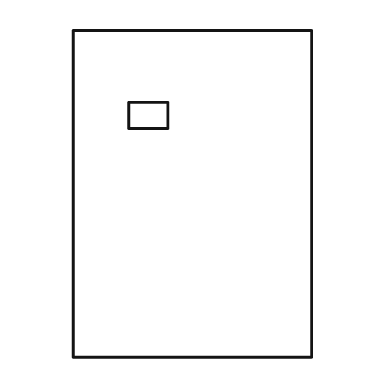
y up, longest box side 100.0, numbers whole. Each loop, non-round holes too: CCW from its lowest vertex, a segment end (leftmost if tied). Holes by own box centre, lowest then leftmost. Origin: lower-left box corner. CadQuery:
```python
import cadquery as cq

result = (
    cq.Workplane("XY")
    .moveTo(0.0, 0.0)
    .lineTo(73.0, 0.0)
    .lineTo(73.0, 100.0)
    .lineTo(0.0, 100.0)
    .close()
    .moveTo(17.0, 70.0)
    .lineTo(29.0, 70.0)
    .lineTo(29.0, 78.0)
    .lineTo(17.0, 78.0)
    .close()
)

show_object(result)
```